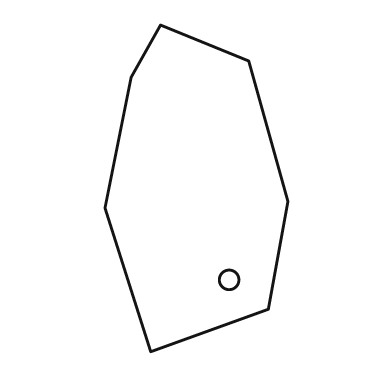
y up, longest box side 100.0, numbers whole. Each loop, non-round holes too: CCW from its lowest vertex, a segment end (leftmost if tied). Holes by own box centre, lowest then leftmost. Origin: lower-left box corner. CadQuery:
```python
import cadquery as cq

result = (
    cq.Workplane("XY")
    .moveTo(14.0, 0.0)
    .lineTo(50.0, 13.0)
    .lineTo(56.0, 46.0)
    .lineTo(44.0, 89.0)
    .lineTo(17.0, 100.0)
    .lineTo(8.0, 84.0)
    .lineTo(0.0, 44.0)
    .close()
    .moveTo(38.0, 22.0)
    .circle(3.0)
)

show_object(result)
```